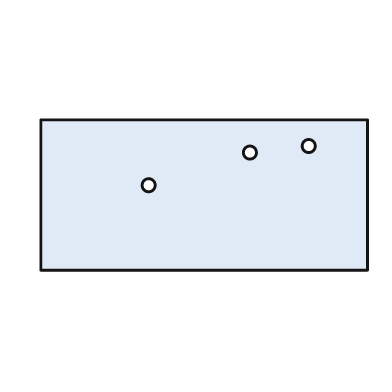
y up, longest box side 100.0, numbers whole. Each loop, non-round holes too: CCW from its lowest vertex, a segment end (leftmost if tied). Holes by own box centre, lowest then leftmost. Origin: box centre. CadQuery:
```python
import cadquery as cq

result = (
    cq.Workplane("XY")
    .moveTo(-50.0, -23.0)
    .lineTo(50.0, -23.0)
    .lineTo(50.0, 23.0)
    .lineTo(-50.0, 23.0)
    .close()
    .moveTo(-17.0, 3.0)
    .circle(2.0)
    .moveTo(14.0, 13.0)
    .circle(2.0)
    .moveTo(32.0, 15.0)
    .circle(2.0)
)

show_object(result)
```